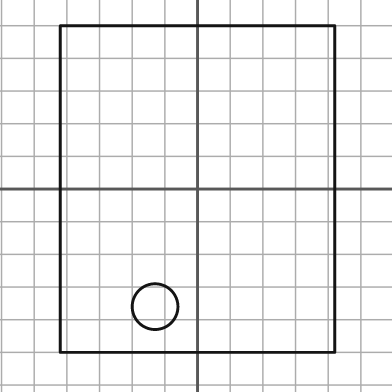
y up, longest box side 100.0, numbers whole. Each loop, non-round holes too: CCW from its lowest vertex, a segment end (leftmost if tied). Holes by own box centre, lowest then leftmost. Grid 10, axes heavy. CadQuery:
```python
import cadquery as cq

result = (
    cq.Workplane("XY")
    .moveTo(-42.0, -50.0)
    .lineTo(42.0, -50.0)
    .lineTo(42.0, 50.0)
    .lineTo(-42.0, 50.0)
    .close()
    .moveTo(-13.0, -36.0)
    .circle(7.0)
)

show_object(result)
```